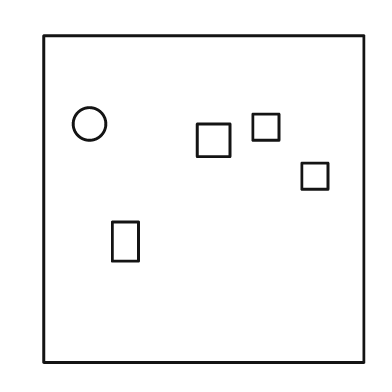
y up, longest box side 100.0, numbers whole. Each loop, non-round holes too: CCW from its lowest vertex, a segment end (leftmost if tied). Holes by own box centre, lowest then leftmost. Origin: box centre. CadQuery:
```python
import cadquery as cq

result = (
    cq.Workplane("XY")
    .moveTo(-49.0, -50.0)
    .lineTo(49.0, -50.0)
    .lineTo(49.0, 50.0)
    .lineTo(-49.0, 50.0)
    .close()
    .moveTo(-28.0, -19.0)
    .lineTo(-20.0, -19.0)
    .lineTo(-20.0, -7.0)
    .lineTo(-28.0, -7.0)
    .close()
    .moveTo(30.0, 3.0)
    .lineTo(38.0, 3.0)
    .lineTo(38.0, 11.0)
    .lineTo(30.0, 11.0)
    .close()
    .moveTo(-2.0, 13.0)
    .lineTo(8.0, 13.0)
    .lineTo(8.0, 23.0)
    .lineTo(-2.0, 23.0)
    .close()
    .moveTo(15.0, 18.0)
    .lineTo(23.0, 18.0)
    .lineTo(23.0, 26.0)
    .lineTo(15.0, 26.0)
    .close()
    .moveTo(-35.0, 23.0)
    .circle(5.0)
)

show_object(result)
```